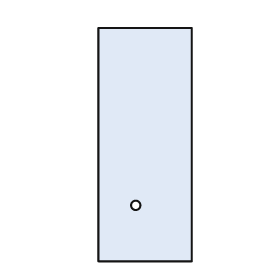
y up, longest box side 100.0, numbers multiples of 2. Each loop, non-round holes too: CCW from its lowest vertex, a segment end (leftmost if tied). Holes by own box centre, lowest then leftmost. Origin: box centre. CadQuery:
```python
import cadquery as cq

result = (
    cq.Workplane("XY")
    .moveTo(-20.0, -50.0)
    .lineTo(20.0, -50.0)
    .lineTo(20.0, 50.0)
    .lineTo(-20.0, 50.0)
    .close()
    .moveTo(-4.0, -26.0)
    .circle(2.0)
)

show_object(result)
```